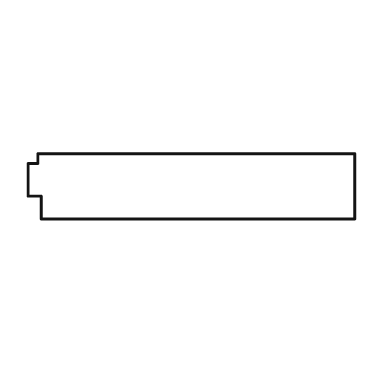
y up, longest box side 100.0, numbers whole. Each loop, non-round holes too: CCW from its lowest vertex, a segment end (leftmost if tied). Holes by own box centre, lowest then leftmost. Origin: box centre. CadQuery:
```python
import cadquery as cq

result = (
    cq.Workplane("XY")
    .moveTo(-46.0, -10.0)
    .lineTo(50.0, -10.0)
    .lineTo(50.0, 10.0)
    .lineTo(-47.0, 10.0)
    .lineTo(-47.0, 7.0)
    .lineTo(-50.0, 7.0)
    .lineTo(-50.0, -3.0)
    .lineTo(-46.0, -3.0)
    .close()
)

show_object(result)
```